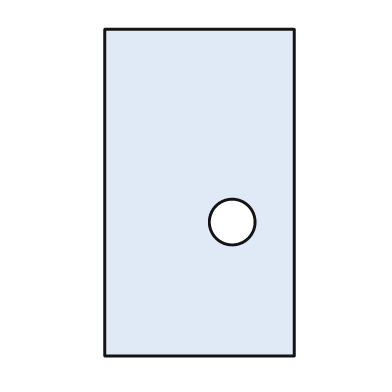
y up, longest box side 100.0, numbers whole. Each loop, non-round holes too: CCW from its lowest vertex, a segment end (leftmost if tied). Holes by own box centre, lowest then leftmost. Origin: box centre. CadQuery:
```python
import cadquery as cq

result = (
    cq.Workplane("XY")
    .moveTo(-29.0, -50.0)
    .lineTo(29.0, -50.0)
    .lineTo(29.0, 50.0)
    .lineTo(-29.0, 50.0)
    .close()
    .moveTo(10.0, -9.0)
    .circle(7.0)
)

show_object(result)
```